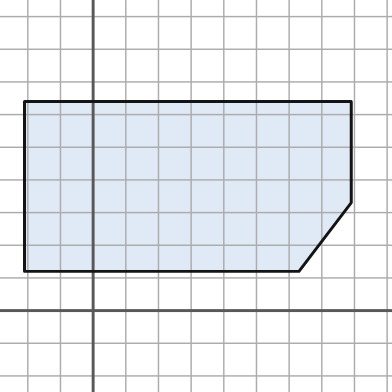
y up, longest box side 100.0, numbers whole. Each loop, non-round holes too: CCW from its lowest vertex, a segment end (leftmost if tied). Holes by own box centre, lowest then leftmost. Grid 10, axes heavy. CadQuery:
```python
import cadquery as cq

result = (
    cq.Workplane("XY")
    .moveTo(-21.0, 12.0)
    .lineTo(63.0, 12.0)
    .lineTo(79.0, 33.0)
    .lineTo(79.0, 64.0)
    .lineTo(-21.0, 64.0)
    .close()
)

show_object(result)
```